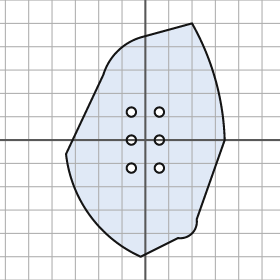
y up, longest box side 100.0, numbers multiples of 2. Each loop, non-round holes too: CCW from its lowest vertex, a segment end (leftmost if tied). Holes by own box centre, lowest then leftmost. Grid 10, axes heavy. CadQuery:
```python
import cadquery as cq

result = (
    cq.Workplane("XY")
    .moveTo(-2.0, -50.0)
    .lineTo(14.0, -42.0)
    .threePointArc((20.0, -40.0), (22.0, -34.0))
    .lineTo(34.0, 0.0)
    .threePointArc((30.0, 26.0), (20.0, 50.0))
    .lineTo(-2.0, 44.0)
    .threePointArc((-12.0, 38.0), (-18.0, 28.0))
    .lineTo(-34.0, -6.0)
    .threePointArc((-24.0, -32.0), (-2.0, -50.0))
    .close()
    .moveTo(-6.0, -12.0)
    .circle(2.0)
    .moveTo(6.0, -12.0)
    .circle(2.0)
    .moveTo(-6.0, 0.0)
    .circle(2.0)
    .moveTo(6.0, 0.0)
    .circle(2.0)
    .moveTo(-6.0, 12.0)
    .circle(2.0)
    .moveTo(6.0, 12.0)
    .circle(2.0)
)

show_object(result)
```